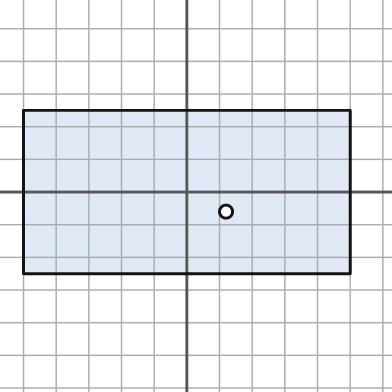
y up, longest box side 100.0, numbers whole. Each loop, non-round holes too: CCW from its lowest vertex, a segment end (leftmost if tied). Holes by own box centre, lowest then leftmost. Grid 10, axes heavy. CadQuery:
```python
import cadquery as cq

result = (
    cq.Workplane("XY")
    .moveTo(-50.0, -25.0)
    .lineTo(50.0, -25.0)
    .lineTo(50.0, 25.0)
    .lineTo(-50.0, 25.0)
    .close()
    .moveTo(12.0, -6.0)
    .circle(2.0)
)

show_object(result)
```